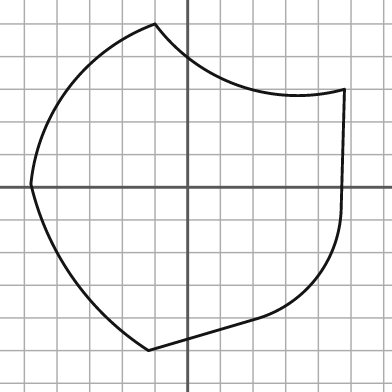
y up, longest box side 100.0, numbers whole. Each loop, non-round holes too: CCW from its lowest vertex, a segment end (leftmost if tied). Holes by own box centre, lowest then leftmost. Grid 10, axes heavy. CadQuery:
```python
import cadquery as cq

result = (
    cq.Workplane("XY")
    .moveTo(-12.0, -50.0)
    .lineTo(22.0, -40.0)
    .threePointArc((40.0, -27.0), (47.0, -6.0))
    .lineTo(48.0, 30.0)
    .threePointArc((16.0, 31.0), (-10.0, 50.0))
    .threePointArc((-36.0, 31.0), (-48.0, 1.0))
    .threePointArc((-35.0, -28.0), (-12.0, -50.0))
    .close()
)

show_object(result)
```